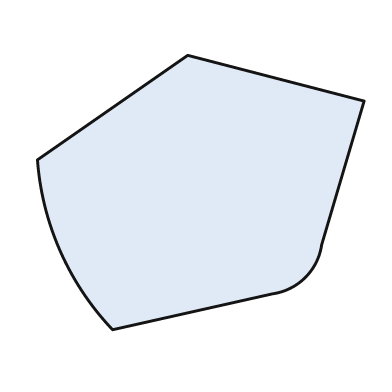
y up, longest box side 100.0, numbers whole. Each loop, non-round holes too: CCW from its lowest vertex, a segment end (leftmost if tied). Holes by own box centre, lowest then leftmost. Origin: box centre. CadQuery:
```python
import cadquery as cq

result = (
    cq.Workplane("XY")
    .moveTo(-27.0, -42.0)
    .lineTo(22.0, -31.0)
    .threePointArc((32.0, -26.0), (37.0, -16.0))
    .lineTo(50.0, 28.0)
    .lineTo(-4.0, 42.0)
    .lineTo(-50.0, 10.0)
    .threePointArc((-43.0, -18.0), (-27.0, -42.0))
    .close()
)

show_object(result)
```